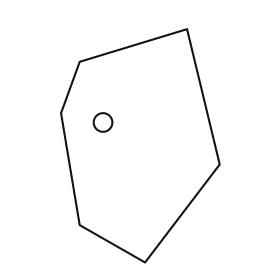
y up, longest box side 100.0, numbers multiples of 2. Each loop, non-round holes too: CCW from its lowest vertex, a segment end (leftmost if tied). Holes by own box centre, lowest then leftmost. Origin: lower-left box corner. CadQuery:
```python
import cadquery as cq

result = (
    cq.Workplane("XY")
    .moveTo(36.0, 0.0)
    .lineTo(68.0, 42.0)
    .lineTo(54.0, 100.0)
    .lineTo(8.0, 86.0)
    .lineTo(0.0, 64.0)
    .lineTo(8.0, 16.0)
    .close()
    .moveTo(18.0, 60.0)
    .circle(4.0)
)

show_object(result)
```